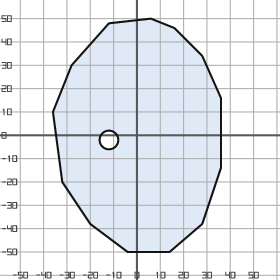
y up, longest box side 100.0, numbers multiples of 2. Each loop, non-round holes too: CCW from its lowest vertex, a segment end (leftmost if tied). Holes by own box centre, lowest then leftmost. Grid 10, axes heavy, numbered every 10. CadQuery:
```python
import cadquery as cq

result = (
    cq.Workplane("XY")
    .moveTo(-4.0, -50.0)
    .lineTo(14.0, -50.0)
    .lineTo(28.0, -38.0)
    .lineTo(36.0, -14.0)
    .lineTo(36.0, 16.0)
    .lineTo(28.0, 34.0)
    .lineTo(16.0, 46.0)
    .lineTo(6.0, 50.0)
    .lineTo(-12.0, 48.0)
    .lineTo(-28.0, 30.0)
    .lineTo(-36.0, 10.0)
    .lineTo(-32.0, -20.0)
    .lineTo(-20.0, -38.0)
    .close()
    .moveTo(-12.0, -2.0)
    .circle(4.0)
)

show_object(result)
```